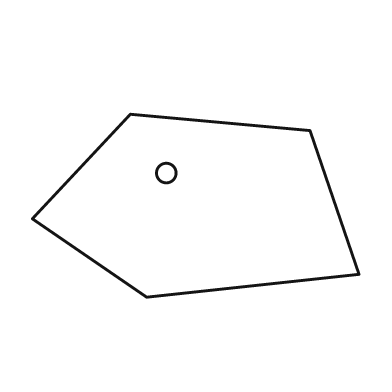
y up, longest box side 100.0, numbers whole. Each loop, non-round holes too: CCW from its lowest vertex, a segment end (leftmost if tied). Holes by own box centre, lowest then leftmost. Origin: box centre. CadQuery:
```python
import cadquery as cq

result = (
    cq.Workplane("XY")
    .moveTo(-15.0, -28.0)
    .lineTo(50.0, -21.0)
    .lineTo(35.0, 23.0)
    .lineTo(-20.0, 28.0)
    .lineTo(-50.0, -4.0)
    .close()
    .moveTo(-9.0, 10.0)
    .circle(3.0)
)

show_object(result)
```